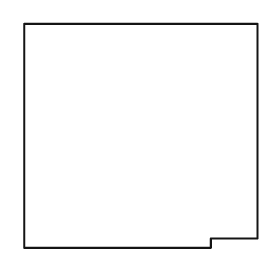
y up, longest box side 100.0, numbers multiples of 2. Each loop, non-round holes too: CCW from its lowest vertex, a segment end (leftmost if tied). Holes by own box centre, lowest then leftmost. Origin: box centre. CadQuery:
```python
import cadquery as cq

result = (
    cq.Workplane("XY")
    .moveTo(-50.0, -48.0)
    .lineTo(30.0, -48.0)
    .lineTo(30.0, -44.0)
    .lineTo(50.0, -44.0)
    .lineTo(50.0, 48.0)
    .lineTo(-50.0, 48.0)
    .close()
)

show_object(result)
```